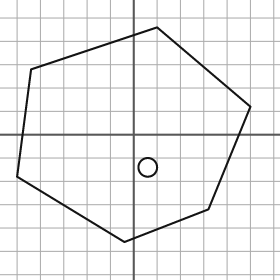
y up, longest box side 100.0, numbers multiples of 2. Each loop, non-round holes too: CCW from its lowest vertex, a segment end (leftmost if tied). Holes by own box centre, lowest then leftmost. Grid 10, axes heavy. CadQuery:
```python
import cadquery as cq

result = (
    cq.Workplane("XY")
    .moveTo(-4.0, -46.0)
    .lineTo(32.0, -32.0)
    .lineTo(50.0, 12.0)
    .lineTo(10.0, 46.0)
    .lineTo(-44.0, 28.0)
    .lineTo(-50.0, -18.0)
    .close()
    .moveTo(6.0, -14.0)
    .circle(4.0)
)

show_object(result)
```